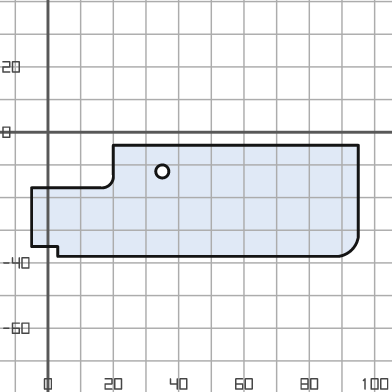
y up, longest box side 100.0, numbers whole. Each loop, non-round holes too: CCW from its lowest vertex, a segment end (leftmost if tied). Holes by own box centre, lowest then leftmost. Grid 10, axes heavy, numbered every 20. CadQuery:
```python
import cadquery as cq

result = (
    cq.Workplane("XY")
    .moveTo(3.0, -38.0)
    .lineTo(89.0, -38.0)
    .threePointArc((93.0, -36.0), (95.0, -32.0))
    .lineTo(95.0, -4.0)
    .lineTo(20.0, -4.0)
    .lineTo(20.0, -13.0)
    .threePointArc((19.0, -16.0), (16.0, -17.0))
    .lineTo(-5.0, -17.0)
    .lineTo(-5.0, -35.0)
    .lineTo(3.0, -35.0)
    .close()
    .moveTo(35.0, -12.0)
    .circle(2.0)
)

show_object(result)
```